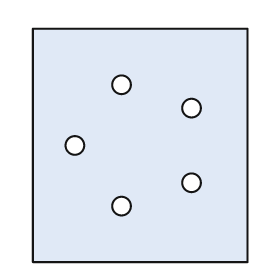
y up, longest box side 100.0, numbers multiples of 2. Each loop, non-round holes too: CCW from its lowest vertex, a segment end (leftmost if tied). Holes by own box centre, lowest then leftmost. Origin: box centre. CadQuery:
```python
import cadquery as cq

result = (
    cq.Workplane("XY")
    .moveTo(-46.0, -50.0)
    .lineTo(46.0, -50.0)
    .lineTo(46.0, 50.0)
    .lineTo(-46.0, 50.0)
    .close()
    .moveTo(-8.0, -26.0)
    .circle(4.0)
    .moveTo(22.0, -16.0)
    .circle(4.0)
    .moveTo(-28.0, 0.0)
    .circle(4.0)
    .moveTo(22.0, 16.0)
    .circle(4.0)
    .moveTo(-8.0, 26.0)
    .circle(4.0)
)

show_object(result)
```